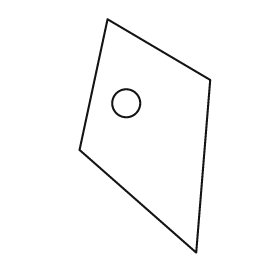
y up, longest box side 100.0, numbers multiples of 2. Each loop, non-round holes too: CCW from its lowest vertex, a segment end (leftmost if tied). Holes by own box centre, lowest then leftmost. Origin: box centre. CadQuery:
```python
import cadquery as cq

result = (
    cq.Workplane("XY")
    .moveTo(22.0, -50.0)
    .lineTo(28.0, 24.0)
    .lineTo(-16.0, 50.0)
    .lineTo(-28.0, -6.0)
    .close()
    .moveTo(-8.0, 14.0)
    .circle(6.0)
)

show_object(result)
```